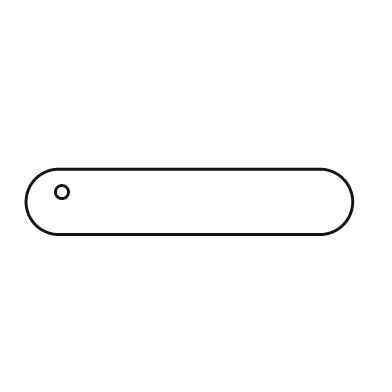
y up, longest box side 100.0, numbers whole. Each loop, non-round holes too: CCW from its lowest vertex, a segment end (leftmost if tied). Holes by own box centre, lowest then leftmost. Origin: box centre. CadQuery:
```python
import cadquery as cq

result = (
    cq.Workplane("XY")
    .moveTo(-40.0, -10.0)
    .lineTo(40.0, -10.0)
    .threePointArc((50.0, 0.0), (40.0, 10.0))
    .lineTo(-40.0, 10.0)
    .threePointArc((-50.0, 0.0), (-40.0, -10.0))
    .close()
    .moveTo(-39.0, 3.0)
    .circle(2.0)
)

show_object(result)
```